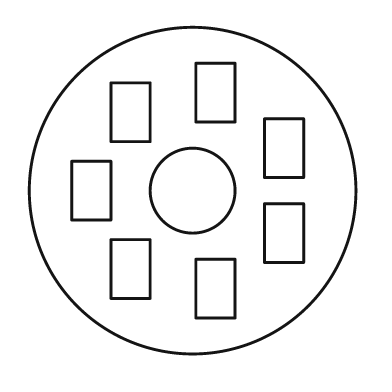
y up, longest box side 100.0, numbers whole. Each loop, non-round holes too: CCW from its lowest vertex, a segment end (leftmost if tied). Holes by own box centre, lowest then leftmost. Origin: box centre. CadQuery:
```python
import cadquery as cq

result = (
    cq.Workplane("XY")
    .moveTo(0.0, 0.0)
    .circle(50.0)
    .moveTo(1.0, -39.0)
    .lineTo(13.0, -39.0)
    .lineTo(13.0, -21.0)
    .lineTo(1.0, -21.0)
    .close()
    .moveTo(-25.0, -33.0)
    .lineTo(-13.0, -33.0)
    .lineTo(-13.0, -15.0)
    .lineTo(-25.0, -15.0)
    .close()
    .moveTo(22.0, -22.0)
    .lineTo(34.0, -22.0)
    .lineTo(34.0, -4.0)
    .lineTo(22.0, -4.0)
    .close()
    .moveTo(-37.0, -9.0)
    .lineTo(-25.0, -9.0)
    .lineTo(-25.0, 9.0)
    .lineTo(-37.0, 9.0)
    .close()
    .moveTo(0.0, 0.0)
    .circle(13.0)
    .moveTo(22.0, 4.0)
    .lineTo(34.0, 4.0)
    .lineTo(34.0, 22.0)
    .lineTo(22.0, 22.0)
    .close()
    .moveTo(-25.0, 15.0)
    .lineTo(-13.0, 15.0)
    .lineTo(-13.0, 33.0)
    .lineTo(-25.0, 33.0)
    .close()
    .moveTo(1.0, 21.0)
    .lineTo(13.0, 21.0)
    .lineTo(13.0, 39.0)
    .lineTo(1.0, 39.0)
    .close()
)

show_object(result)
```